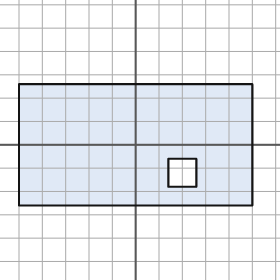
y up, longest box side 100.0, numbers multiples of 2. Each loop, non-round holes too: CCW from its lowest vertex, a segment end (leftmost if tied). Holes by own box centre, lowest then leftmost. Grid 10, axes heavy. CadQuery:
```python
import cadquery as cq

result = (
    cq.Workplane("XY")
    .moveTo(-50.0, -26.0)
    .lineTo(50.0, -26.0)
    .lineTo(50.0, 26.0)
    .lineTo(-50.0, 26.0)
    .close()
    .moveTo(14.0, -18.0)
    .lineTo(26.0, -18.0)
    .lineTo(26.0, -6.0)
    .lineTo(14.0, -6.0)
    .close()
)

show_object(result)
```